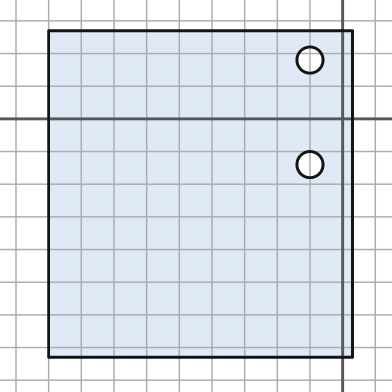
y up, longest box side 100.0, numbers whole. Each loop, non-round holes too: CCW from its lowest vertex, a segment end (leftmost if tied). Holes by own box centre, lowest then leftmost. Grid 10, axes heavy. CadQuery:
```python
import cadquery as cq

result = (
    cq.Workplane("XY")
    .moveTo(-90.0, -73.0)
    .lineTo(3.0, -73.0)
    .lineTo(3.0, 27.0)
    .lineTo(-90.0, 27.0)
    .close()
    .moveTo(-10.0, -14.0)
    .circle(4.0)
    .moveTo(-10.0, 18.0)
    .circle(4.0)
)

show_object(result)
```